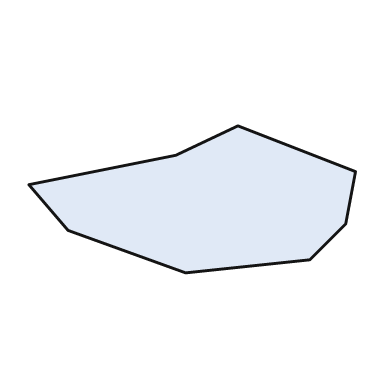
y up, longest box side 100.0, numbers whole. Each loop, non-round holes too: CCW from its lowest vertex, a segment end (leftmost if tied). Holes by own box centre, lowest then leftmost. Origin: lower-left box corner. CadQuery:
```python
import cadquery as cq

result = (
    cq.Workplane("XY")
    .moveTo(48.0, 0.0)
    .lineTo(86.0, 4.0)
    .lineTo(97.0, 15.0)
    .lineTo(100.0, 31.0)
    .lineTo(64.0, 45.0)
    .lineTo(45.0, 36.0)
    .lineTo(0.0, 27.0)
    .lineTo(12.0, 13.0)
    .close()
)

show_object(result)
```